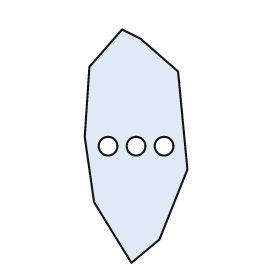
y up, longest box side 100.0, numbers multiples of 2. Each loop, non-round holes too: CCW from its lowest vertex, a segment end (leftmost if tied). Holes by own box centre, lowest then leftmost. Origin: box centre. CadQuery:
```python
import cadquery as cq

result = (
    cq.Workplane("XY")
    .moveTo(-2.0, -50.0)
    .lineTo(10.0, -40.0)
    .lineTo(22.0, -10.0)
    .lineTo(18.0, 32.0)
    .lineTo(2.0, 46.0)
    .lineTo(-6.0, 50.0)
    .lineTo(-20.0, 34.0)
    .lineTo(-22.0, 4.0)
    .lineTo(-18.0, -24.0)
    .close()
    .moveTo(-12.0, 0.0)
    .circle(4.0)
    .moveTo(0.0, 0.0)
    .circle(4.0)
    .moveTo(12.0, 0.0)
    .circle(4.0)
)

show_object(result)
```